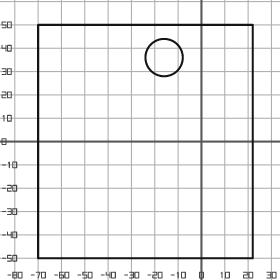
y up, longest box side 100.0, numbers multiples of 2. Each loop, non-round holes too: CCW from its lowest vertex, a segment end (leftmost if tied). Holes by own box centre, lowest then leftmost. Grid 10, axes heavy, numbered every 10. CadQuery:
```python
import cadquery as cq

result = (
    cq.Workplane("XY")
    .moveTo(-70.0, -50.0)
    .lineTo(22.0, -50.0)
    .lineTo(22.0, 50.0)
    .lineTo(-70.0, 50.0)
    .close()
    .moveTo(-16.0, 36.0)
    .circle(8.0)
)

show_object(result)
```